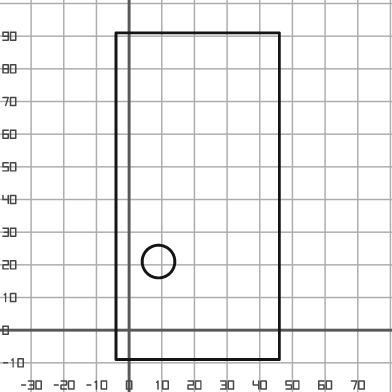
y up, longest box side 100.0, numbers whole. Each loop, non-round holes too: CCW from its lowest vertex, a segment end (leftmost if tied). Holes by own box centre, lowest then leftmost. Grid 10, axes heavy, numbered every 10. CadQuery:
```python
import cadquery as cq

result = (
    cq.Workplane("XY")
    .moveTo(-4.0, -9.0)
    .lineTo(46.0, -9.0)
    .lineTo(46.0, 91.0)
    .lineTo(-4.0, 91.0)
    .close()
    .moveTo(9.0, 21.0)
    .circle(5.0)
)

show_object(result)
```